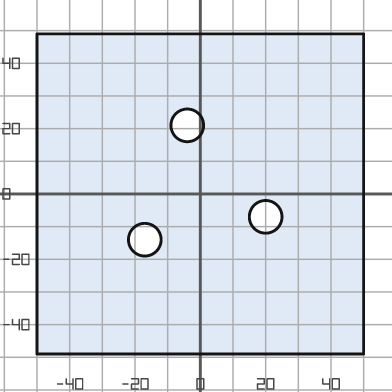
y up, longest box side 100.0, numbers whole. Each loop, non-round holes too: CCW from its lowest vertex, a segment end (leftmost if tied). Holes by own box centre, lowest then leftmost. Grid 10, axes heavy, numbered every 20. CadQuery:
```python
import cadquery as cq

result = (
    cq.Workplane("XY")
    .moveTo(-50.0, -49.0)
    .lineTo(50.0, -49.0)
    .lineTo(50.0, 49.0)
    .lineTo(-50.0, 49.0)
    .close()
    .moveTo(-17.0, -14.0)
    .circle(5.0)
    .moveTo(20.0, -7.0)
    .circle(5.0)
    .moveTo(-4.0, 21.0)
    .circle(5.0)
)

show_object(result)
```